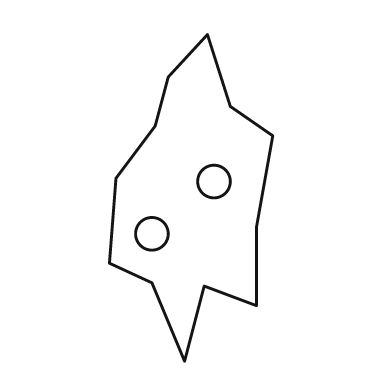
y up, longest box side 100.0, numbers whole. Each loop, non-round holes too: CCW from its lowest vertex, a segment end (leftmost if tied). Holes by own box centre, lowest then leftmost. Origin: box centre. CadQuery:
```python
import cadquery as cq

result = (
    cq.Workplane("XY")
    .moveTo(-2.0, -50.0)
    .lineTo(4.0, -27.0)
    .lineTo(20.0, -33.0)
    .lineTo(20.0, -9.0)
    .lineTo(25.0, 19.0)
    .lineTo(12.0, 28.0)
    .lineTo(5.0, 50.0)
    .lineTo(-7.0, 37.0)
    .lineTo(-11.0, 22.0)
    .lineTo(-23.0, 6.0)
    .lineTo(-25.0, -20.0)
    .lineTo(-12.0, -26.0)
    .close()
    .moveTo(-12.0, -11.0)
    .circle(5.0)
    .moveTo(7.0, 5.0)
    .circle(5.0)
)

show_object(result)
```